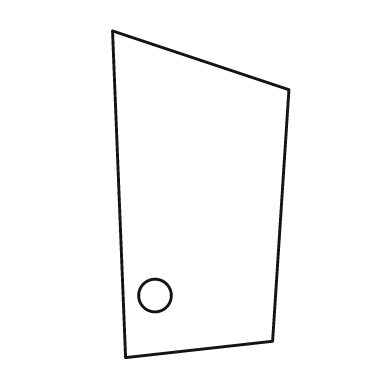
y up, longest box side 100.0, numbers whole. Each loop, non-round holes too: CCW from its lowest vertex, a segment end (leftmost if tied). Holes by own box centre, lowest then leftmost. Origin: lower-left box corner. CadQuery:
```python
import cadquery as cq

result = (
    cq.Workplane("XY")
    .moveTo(4.0, 0.0)
    .lineTo(49.0, 5.0)
    .lineTo(54.0, 82.0)
    .lineTo(0.0, 100.0)
    .close()
    .moveTo(13.0, 19.0)
    .circle(5.0)
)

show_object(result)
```